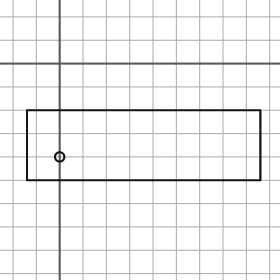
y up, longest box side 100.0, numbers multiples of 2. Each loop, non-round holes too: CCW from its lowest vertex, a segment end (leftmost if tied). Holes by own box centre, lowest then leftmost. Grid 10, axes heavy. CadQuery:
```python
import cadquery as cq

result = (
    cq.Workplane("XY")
    .moveTo(-14.0, -50.0)
    .lineTo(86.0, -50.0)
    .lineTo(86.0, -20.0)
    .lineTo(-14.0, -20.0)
    .close()
    .moveTo(0.0, -40.0)
    .circle(2.0)
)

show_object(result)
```